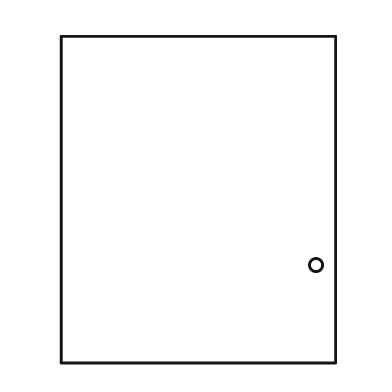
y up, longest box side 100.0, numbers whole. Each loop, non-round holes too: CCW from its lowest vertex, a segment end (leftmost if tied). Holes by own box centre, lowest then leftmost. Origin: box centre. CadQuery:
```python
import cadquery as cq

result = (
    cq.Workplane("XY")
    .moveTo(-42.0, -50.0)
    .lineTo(42.0, -50.0)
    .lineTo(42.0, 50.0)
    .lineTo(-42.0, 50.0)
    .close()
    .moveTo(36.0, -20.0)
    .circle(2.0)
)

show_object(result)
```